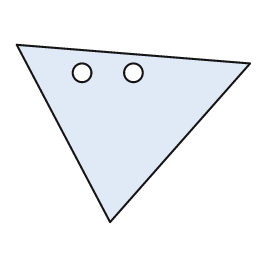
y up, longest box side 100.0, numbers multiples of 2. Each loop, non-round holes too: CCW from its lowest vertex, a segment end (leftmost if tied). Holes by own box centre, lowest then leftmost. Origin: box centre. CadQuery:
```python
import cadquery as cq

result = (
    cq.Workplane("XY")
    .moveTo(-10.0, -38.0)
    .lineTo(50.0, 30.0)
    .lineTo(-50.0, 38.0)
    .close()
    .moveTo(-22.0, 26.0)
    .circle(4.0)
    .moveTo(0.0, 26.0)
    .circle(4.0)
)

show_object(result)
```